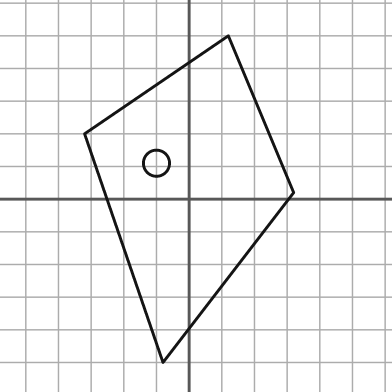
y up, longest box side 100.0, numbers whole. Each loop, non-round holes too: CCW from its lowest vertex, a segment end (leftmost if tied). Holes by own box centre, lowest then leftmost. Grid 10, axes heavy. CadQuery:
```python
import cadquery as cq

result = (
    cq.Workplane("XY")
    .moveTo(-8.0, -50.0)
    .lineTo(32.0, 2.0)
    .lineTo(12.0, 50.0)
    .lineTo(-32.0, 20.0)
    .close()
    .moveTo(-10.0, 11.0)
    .circle(4.0)
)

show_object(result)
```